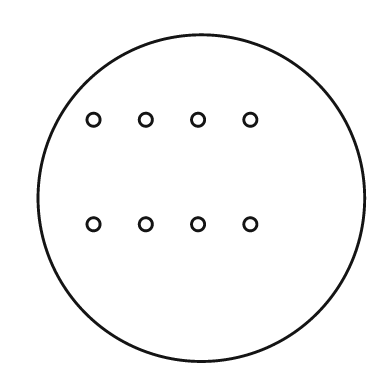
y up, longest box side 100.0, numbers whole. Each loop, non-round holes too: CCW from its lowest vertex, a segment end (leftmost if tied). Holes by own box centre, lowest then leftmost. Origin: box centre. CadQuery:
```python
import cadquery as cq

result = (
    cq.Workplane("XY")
    .moveTo(0.0, 0.0)
    .circle(50.0)
    .moveTo(-33.0, -8.0)
    .circle(2.0)
    .moveTo(-17.0, -8.0)
    .circle(2.0)
    .moveTo(-1.0, -8.0)
    .circle(2.0)
    .moveTo(15.0, -8.0)
    .circle(2.0)
    .moveTo(-33.0, 24.0)
    .circle(2.0)
    .moveTo(-17.0, 24.0)
    .circle(2.0)
    .moveTo(-1.0, 24.0)
    .circle(2.0)
    .moveTo(15.0, 24.0)
    .circle(2.0)
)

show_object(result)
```